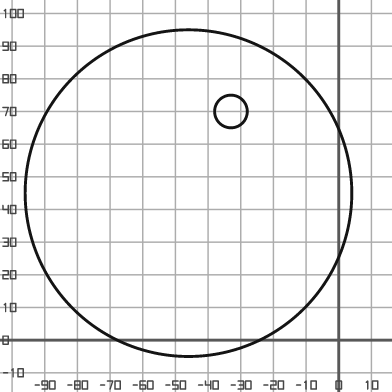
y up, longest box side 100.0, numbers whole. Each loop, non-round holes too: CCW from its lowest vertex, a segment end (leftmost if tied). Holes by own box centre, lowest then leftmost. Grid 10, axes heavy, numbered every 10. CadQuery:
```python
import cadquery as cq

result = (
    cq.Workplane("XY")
    .moveTo(-46.0, 45.0)
    .circle(50.0)
    .moveTo(-33.0, 70.0)
    .circle(5.0)
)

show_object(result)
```